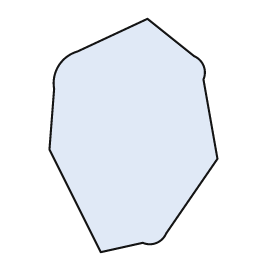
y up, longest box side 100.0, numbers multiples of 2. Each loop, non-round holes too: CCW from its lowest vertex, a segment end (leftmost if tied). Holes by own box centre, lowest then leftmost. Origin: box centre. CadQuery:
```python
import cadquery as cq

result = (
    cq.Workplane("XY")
    .moveTo(-14.0, -50.0)
    .lineTo(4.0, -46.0)
    .threePointArc((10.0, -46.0), (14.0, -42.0))
    .lineTo(36.0, -10.0)
    .lineTo(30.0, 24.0)
    .threePointArc((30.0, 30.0), (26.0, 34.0))
    .lineTo(6.0, 50.0)
    .lineTo(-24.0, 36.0)
    .threePointArc((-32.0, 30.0), (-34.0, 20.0))
    .lineTo(-36.0, -6.0)
    .close()
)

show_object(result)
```